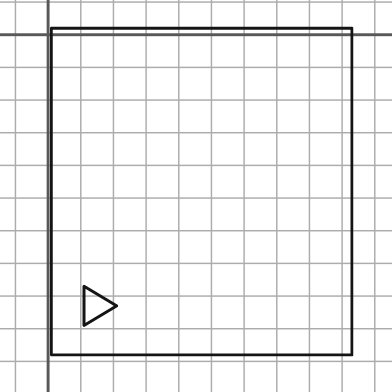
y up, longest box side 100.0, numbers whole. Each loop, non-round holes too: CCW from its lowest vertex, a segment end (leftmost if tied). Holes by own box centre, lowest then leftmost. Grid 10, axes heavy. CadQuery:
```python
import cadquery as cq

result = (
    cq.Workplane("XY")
    .moveTo(1.0, -98.0)
    .lineTo(93.0, -98.0)
    .lineTo(93.0, 2.0)
    .lineTo(1.0, 2.0)
    .close()
    .moveTo(11.0, -89.0)
    .lineTo(21.0, -83.0)
    .lineTo(11.0, -77.0)
    .close()
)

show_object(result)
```